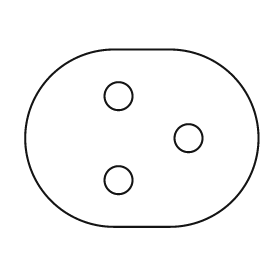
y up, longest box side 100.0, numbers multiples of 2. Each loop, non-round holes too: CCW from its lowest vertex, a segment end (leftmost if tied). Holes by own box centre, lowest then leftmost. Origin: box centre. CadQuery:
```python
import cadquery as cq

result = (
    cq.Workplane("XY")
    .moveTo(-12.0, -38.0)
    .lineTo(12.0, -38.0)
    .threePointArc((50.0, 0.0), (12.0, 38.0))
    .lineTo(-12.0, 38.0)
    .threePointArc((-50.0, 0.0), (-12.0, -38.0))
    .close()
    .moveTo(-10.0, -18.0)
    .circle(6.0)
    .moveTo(20.0, 0.0)
    .circle(6.0)
    .moveTo(-10.0, 18.0)
    .circle(6.0)
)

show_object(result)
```